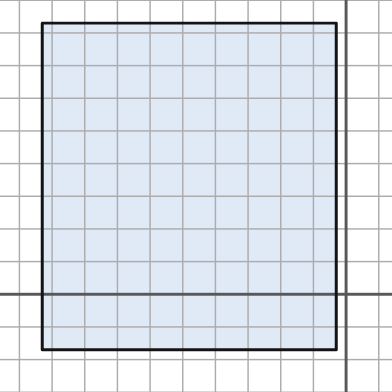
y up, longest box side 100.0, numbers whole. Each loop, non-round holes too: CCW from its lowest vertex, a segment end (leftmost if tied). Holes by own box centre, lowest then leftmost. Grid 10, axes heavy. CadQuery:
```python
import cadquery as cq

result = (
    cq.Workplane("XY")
    .moveTo(-93.0, -17.0)
    .lineTo(-3.0, -17.0)
    .lineTo(-3.0, 83.0)
    .lineTo(-93.0, 83.0)
    .close()
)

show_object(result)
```